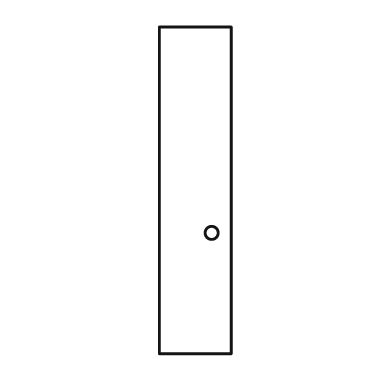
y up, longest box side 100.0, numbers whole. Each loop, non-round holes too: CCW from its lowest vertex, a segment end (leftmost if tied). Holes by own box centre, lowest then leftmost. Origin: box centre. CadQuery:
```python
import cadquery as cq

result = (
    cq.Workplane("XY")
    .moveTo(-11.0, -50.0)
    .lineTo(11.0, -50.0)
    .lineTo(11.0, 50.0)
    .lineTo(-11.0, 50.0)
    .close()
    .moveTo(5.0, -13.0)
    .circle(2.0)
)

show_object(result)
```